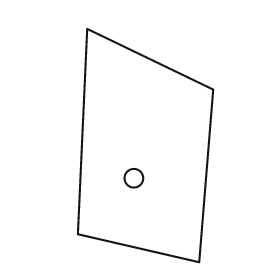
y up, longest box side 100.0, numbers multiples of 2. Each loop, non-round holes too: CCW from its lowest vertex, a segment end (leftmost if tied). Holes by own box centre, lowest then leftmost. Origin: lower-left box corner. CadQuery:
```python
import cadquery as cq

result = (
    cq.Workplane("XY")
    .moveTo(52.0, 0.0)
    .lineTo(58.0, 74.0)
    .lineTo(4.0, 100.0)
    .lineTo(0.0, 12.0)
    .close()
    .moveTo(24.0, 36.0)
    .circle(4.0)
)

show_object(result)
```